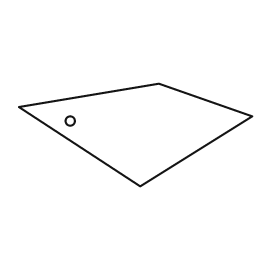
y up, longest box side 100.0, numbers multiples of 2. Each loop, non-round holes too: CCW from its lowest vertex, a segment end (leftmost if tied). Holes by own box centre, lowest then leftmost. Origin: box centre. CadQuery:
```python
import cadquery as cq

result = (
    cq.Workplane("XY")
    .moveTo(2.0, -22.0)
    .lineTo(50.0, 8.0)
    .lineTo(10.0, 22.0)
    .lineTo(-50.0, 12.0)
    .close()
    .moveTo(-28.0, 6.0)
    .circle(2.0)
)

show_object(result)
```